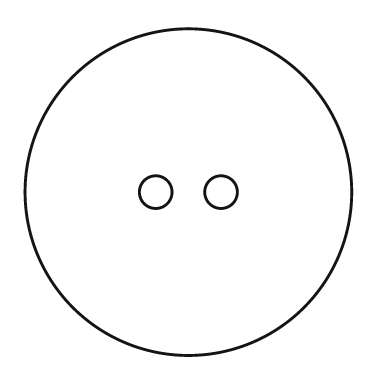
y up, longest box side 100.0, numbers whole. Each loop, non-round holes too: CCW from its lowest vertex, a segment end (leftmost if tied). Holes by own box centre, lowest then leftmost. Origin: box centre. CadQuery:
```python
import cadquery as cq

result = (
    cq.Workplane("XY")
    .moveTo(0.0, 0.0)
    .circle(50.0)
    .moveTo(-10.0, 0.0)
    .circle(5.0)
    .moveTo(10.0, 0.0)
    .circle(5.0)
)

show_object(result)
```